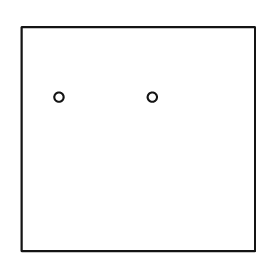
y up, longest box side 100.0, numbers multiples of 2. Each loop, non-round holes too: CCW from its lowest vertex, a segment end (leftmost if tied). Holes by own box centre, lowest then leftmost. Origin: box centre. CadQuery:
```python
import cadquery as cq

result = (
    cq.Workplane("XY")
    .moveTo(-50.0, -48.0)
    .lineTo(50.0, -48.0)
    .lineTo(50.0, 48.0)
    .lineTo(-50.0, 48.0)
    .close()
    .moveTo(-34.0, 18.0)
    .circle(2.0)
    .moveTo(6.0, 18.0)
    .circle(2.0)
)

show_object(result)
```